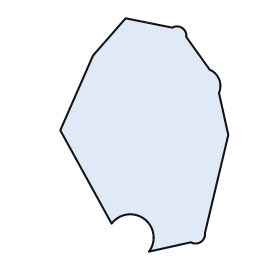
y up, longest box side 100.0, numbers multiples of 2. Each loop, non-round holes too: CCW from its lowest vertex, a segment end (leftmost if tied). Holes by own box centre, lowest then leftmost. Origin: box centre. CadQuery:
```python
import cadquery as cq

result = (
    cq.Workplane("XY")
    .moveTo(2.0, -50.0)
    .lineTo(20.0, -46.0)
    .threePointArc((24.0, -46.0), (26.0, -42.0))
    .lineTo(36.0, 0.0)
    .lineTo(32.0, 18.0)
    .threePointArc((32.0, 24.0), (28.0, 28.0))
    .lineTo(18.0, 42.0)
    .threePointArc((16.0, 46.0), (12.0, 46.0))
    .lineTo(-8.0, 50.0)
    .lineTo(-22.0, 34.0)
    .lineTo(-36.0, 2.0)
    .lineTo(-14.0, -38.0)
    .threePointArc((0.0, -36.0), (2.0, -50.0))
    .close()
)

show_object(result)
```